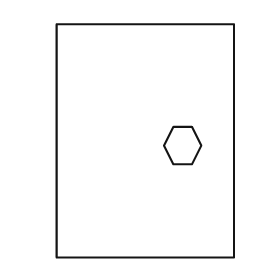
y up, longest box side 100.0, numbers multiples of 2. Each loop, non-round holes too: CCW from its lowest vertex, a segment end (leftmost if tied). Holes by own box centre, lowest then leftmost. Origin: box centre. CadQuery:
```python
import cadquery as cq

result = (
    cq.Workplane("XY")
    .moveTo(-38.0, -50.0)
    .lineTo(38.0, -50.0)
    .lineTo(38.0, 50.0)
    .lineTo(-38.0, 50.0)
    .close()
    .moveTo(12.0, -10.0)
    .lineTo(20.0, -10.0)
    .lineTo(24.0, -2.0)
    .lineTo(20.0, 6.0)
    .lineTo(12.0, 6.0)
    .lineTo(8.0, -2.0)
    .close()
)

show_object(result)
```